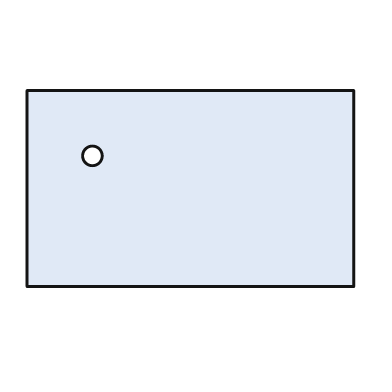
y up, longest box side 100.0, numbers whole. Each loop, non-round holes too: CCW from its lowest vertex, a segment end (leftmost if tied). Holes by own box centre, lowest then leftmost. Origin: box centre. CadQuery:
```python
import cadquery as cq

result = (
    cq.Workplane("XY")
    .moveTo(-50.0, -30.0)
    .lineTo(50.0, -30.0)
    .lineTo(50.0, 30.0)
    .lineTo(-50.0, 30.0)
    .close()
    .moveTo(-30.0, 10.0)
    .circle(3.0)
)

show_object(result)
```